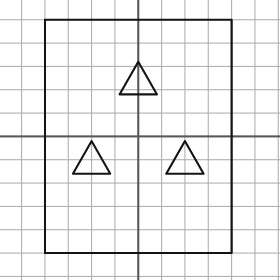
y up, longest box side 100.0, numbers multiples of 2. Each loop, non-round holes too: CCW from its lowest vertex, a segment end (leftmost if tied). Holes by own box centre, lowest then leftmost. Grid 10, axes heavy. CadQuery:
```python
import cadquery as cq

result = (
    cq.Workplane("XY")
    .moveTo(-40.0, -50.0)
    .lineTo(40.0, -50.0)
    .lineTo(40.0, 50.0)
    .lineTo(-40.0, 50.0)
    .close()
    .moveTo(-28.0, -16.0)
    .lineTo(-12.0, -16.0)
    .lineTo(-20.0, -2.0)
    .close()
    .moveTo(12.0, -16.0)
    .lineTo(28.0, -16.0)
    .lineTo(20.0, -2.0)
    .close()
    .moveTo(-8.0, 18.0)
    .lineTo(8.0, 18.0)
    .lineTo(0.0, 32.0)
    .close()
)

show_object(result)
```